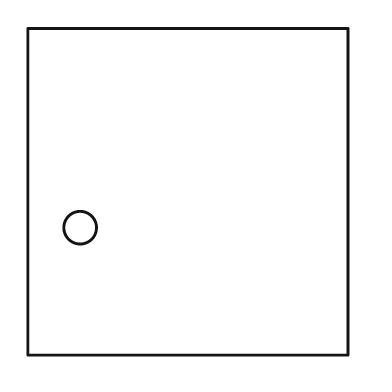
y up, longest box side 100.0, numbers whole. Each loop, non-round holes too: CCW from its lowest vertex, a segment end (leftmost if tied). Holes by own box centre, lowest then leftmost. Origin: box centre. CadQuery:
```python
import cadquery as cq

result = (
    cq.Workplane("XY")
    .moveTo(-49.0, -50.0)
    .lineTo(49.0, -50.0)
    .lineTo(49.0, 50.0)
    .lineTo(-49.0, 50.0)
    .close()
    .moveTo(-33.0, -11.0)
    .circle(5.0)
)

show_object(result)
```